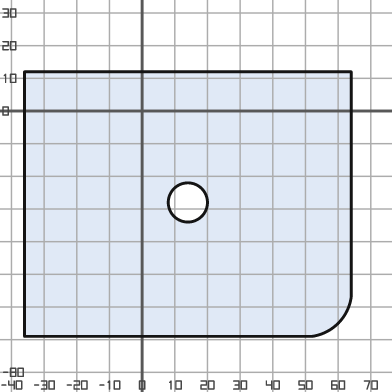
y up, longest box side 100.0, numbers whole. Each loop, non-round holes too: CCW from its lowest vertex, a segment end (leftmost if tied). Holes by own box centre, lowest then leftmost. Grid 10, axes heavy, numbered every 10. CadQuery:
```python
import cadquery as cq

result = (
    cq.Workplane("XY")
    .moveTo(-36.0, -69.0)
    .lineTo(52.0, -69.0)
    .threePointArc((60.0, -65.0), (64.0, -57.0))
    .lineTo(64.0, 12.0)
    .lineTo(-36.0, 12.0)
    .close()
    .moveTo(14.0, -28.0)
    .circle(6.0)
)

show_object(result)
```